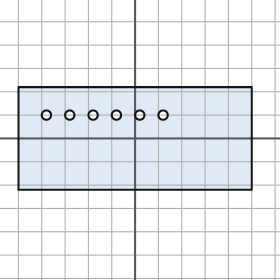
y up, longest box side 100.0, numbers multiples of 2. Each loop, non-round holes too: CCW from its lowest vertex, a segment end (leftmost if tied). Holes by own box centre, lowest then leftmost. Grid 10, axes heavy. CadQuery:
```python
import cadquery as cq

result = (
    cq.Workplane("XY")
    .moveTo(-50.0, -22.0)
    .lineTo(50.0, -22.0)
    .lineTo(50.0, 22.0)
    .lineTo(-50.0, 22.0)
    .close()
    .moveTo(-38.0, 10.0)
    .circle(2.0)
    .moveTo(-28.0, 10.0)
    .circle(2.0)
    .moveTo(-18.0, 10.0)
    .circle(2.0)
    .moveTo(-8.0, 10.0)
    .circle(2.0)
    .moveTo(2.0, 10.0)
    .circle(2.0)
    .moveTo(12.0, 10.0)
    .circle(2.0)
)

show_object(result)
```